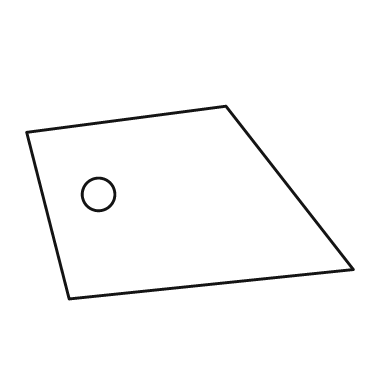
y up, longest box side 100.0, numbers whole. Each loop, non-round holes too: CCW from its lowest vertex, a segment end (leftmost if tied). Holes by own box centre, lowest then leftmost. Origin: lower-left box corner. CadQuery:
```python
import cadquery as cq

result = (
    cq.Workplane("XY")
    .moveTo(13.0, 0.0)
    .lineTo(100.0, 9.0)
    .lineTo(61.0, 59.0)
    .lineTo(0.0, 51.0)
    .close()
    .moveTo(22.0, 32.0)
    .circle(5.0)
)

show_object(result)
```